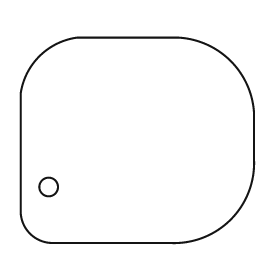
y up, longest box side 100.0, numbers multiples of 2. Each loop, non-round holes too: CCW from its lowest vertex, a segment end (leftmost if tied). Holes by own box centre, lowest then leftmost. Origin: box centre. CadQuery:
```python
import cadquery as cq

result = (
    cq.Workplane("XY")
    .moveTo(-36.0, -44.0)
    .lineTo(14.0, -44.0)
    .threePointArc((40.0, -34.0), (50.0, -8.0))
    .lineTo(50.0, 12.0)
    .threePointArc((40.0, 34.0), (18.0, 44.0))
    .lineTo(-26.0, 44.0)
    .threePointArc((-42.0, 36.0), (-50.0, 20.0))
    .lineTo(-50.0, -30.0)
    .threePointArc((-46.0, -40.0), (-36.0, -44.0))
    .close()
    .moveTo(-38.0, -20.0)
    .circle(4.0)
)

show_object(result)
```